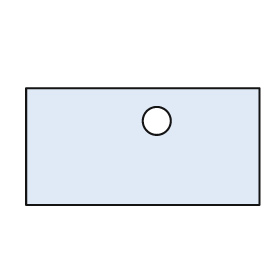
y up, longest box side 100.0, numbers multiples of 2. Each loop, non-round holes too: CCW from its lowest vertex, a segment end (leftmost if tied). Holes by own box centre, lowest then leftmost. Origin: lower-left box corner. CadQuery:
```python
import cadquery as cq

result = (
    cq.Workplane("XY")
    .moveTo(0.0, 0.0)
    .lineTo(100.0, 0.0)
    .lineTo(100.0, 50.0)
    .lineTo(0.0, 50.0)
    .close()
    .moveTo(56.0, 36.0)
    .circle(6.0)
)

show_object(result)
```